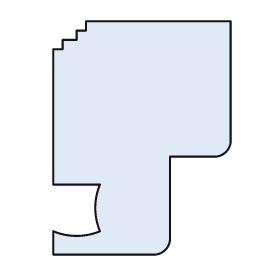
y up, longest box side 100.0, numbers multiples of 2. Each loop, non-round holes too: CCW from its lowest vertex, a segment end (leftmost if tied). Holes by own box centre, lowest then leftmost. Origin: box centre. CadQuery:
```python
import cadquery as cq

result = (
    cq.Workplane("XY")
    .moveTo(-38.0, -50.0)
    .lineTo(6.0, -50.0)
    .threePointArc((10.0, -48.0), (12.0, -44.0))
    .lineTo(12.0, -8.0)
    .lineTo(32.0, -8.0)
    .threePointArc((36.0, -6.0), (38.0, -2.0))
    .lineTo(38.0, 50.0)
    .lineTo(-24.0, 50.0)
    .lineTo(-24.0, 46.0)
    .lineTo(-28.0, 46.0)
    .lineTo(-28.0, 42.0)
    .lineTo(-34.0, 42.0)
    .lineTo(-34.0, 38.0)
    .lineTo(-38.0, 38.0)
    .lineTo(-38.0, -20.0)
    .lineTo(-18.0, -20.0)
    .threePointArc((-20.0, -30.0), (-18.0, -40.0))
    .threePointArc((-28.0, -42.0), (-38.0, -40.0))
    .close()
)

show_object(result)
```